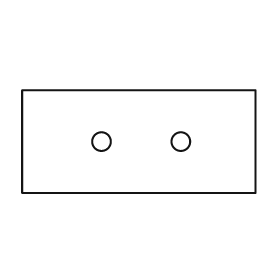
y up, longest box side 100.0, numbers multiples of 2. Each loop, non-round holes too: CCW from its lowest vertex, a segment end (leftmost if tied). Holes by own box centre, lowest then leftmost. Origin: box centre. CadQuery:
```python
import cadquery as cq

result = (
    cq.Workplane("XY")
    .moveTo(-50.0, -22.0)
    .lineTo(50.0, -22.0)
    .lineTo(50.0, 22.0)
    .lineTo(-50.0, 22.0)
    .close()
    .moveTo(-16.0, 0.0)
    .circle(4.0)
    .moveTo(18.0, 0.0)
    .circle(4.0)
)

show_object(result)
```